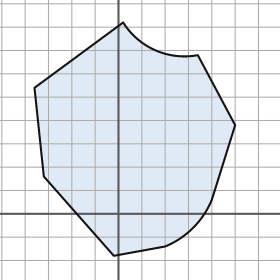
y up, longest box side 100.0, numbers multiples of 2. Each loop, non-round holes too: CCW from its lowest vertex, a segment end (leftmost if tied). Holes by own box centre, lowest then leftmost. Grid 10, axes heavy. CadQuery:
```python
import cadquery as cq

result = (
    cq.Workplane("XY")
    .moveTo(-2.0, -18.0)
    .lineTo(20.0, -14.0)
    .threePointArc((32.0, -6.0), (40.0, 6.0))
    .lineTo(50.0, 38.0)
    .lineTo(34.0, 68.0)
    .threePointArc((16.0, 70.0), (2.0, 82.0))
    .lineTo(-36.0, 54.0)
    .lineTo(-32.0, 16.0)
    .close()
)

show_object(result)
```